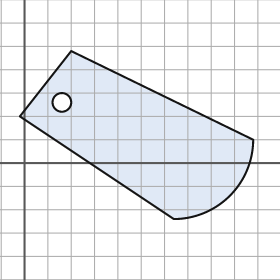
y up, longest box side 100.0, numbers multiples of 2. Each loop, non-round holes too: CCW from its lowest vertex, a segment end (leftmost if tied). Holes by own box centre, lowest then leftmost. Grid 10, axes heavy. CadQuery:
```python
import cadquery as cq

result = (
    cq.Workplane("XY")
    .moveTo(64.0, -24.0)
    .threePointArc((88.0, -14.0), (98.0, 10.0))
    .lineTo(20.0, 48.0)
    .lineTo(-2.0, 20.0)
    .close()
    .moveTo(16.0, 26.0)
    .circle(4.0)
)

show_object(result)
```